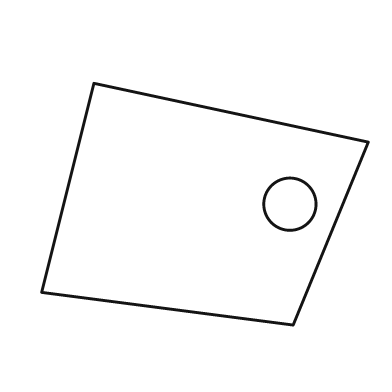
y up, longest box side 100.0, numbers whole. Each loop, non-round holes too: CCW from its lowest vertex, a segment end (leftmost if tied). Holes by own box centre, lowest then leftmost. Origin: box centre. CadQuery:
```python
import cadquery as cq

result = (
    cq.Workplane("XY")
    .moveTo(27.0, -37.0)
    .lineTo(50.0, 19.0)
    .lineTo(-34.0, 37.0)
    .lineTo(-50.0, -27.0)
    .close()
    .moveTo(26.0, 0.0)
    .circle(8.0)
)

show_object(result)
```